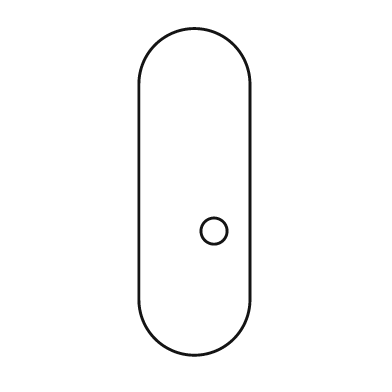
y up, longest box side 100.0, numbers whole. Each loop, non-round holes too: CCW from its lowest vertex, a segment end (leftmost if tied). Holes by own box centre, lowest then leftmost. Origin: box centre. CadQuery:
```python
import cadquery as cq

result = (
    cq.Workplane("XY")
    .moveTo(-17.0, -33.0)
    .threePointArc((0.0, -50.0), (17.0, -33.0))
    .lineTo(17.0, 33.0)
    .threePointArc((0.0, 50.0), (-17.0, 33.0))
    .close()
    .moveTo(6.0, -12.0)
    .circle(4.0)
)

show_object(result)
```